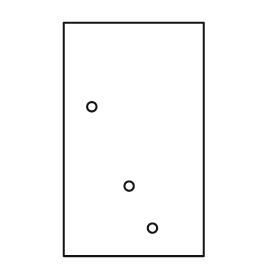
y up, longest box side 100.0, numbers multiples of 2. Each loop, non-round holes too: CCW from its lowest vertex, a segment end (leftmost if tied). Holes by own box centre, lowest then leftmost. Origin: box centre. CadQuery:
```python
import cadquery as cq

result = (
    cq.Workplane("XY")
    .moveTo(-30.0, -50.0)
    .lineTo(30.0, -50.0)
    .lineTo(30.0, 50.0)
    .lineTo(-30.0, 50.0)
    .close()
    .moveTo(8.0, -38.0)
    .circle(2.0)
    .moveTo(-2.0, -20.0)
    .circle(2.0)
    .moveTo(-18.0, 14.0)
    .circle(2.0)
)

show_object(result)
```